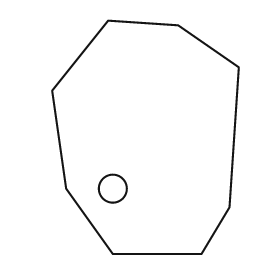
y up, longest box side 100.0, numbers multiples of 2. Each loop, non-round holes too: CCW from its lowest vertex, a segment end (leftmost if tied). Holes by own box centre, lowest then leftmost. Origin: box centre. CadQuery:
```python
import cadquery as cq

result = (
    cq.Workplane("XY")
    .moveTo(-14.0, -50.0)
    .lineTo(24.0, -50.0)
    .lineTo(36.0, -30.0)
    .lineTo(40.0, 30.0)
    .lineTo(14.0, 48.0)
    .lineTo(-16.0, 50.0)
    .lineTo(-40.0, 20.0)
    .lineTo(-34.0, -22.0)
    .close()
    .moveTo(-14.0, -22.0)
    .circle(6.0)
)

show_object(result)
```